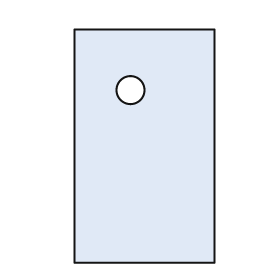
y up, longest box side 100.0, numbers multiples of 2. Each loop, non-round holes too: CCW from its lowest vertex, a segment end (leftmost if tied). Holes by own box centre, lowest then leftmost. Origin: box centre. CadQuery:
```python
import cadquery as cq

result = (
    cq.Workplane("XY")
    .moveTo(-30.0, -50.0)
    .lineTo(30.0, -50.0)
    .lineTo(30.0, 50.0)
    .lineTo(-30.0, 50.0)
    .close()
    .moveTo(-6.0, 24.0)
    .circle(6.0)
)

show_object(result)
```